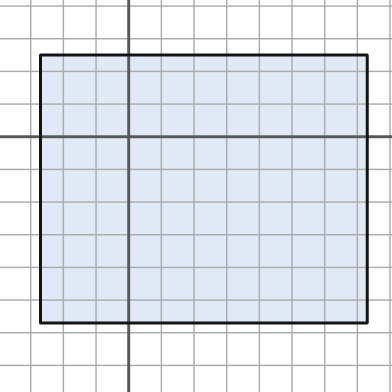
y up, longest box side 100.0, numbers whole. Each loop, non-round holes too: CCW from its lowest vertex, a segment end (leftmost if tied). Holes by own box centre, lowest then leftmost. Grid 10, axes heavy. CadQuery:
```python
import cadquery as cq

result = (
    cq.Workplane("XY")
    .moveTo(-27.0, -57.0)
    .lineTo(73.0, -57.0)
    .lineTo(73.0, 25.0)
    .lineTo(-27.0, 25.0)
    .close()
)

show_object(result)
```